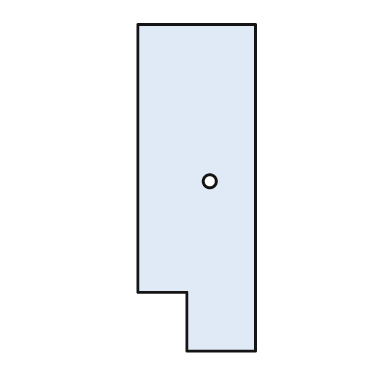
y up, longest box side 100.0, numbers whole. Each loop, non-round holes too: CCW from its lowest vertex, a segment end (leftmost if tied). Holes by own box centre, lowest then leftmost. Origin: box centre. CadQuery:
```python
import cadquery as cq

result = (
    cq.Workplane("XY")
    .moveTo(-3.0, -50.0)
    .lineTo(18.0, -50.0)
    .lineTo(18.0, 50.0)
    .lineTo(-18.0, 50.0)
    .lineTo(-18.0, -32.0)
    .lineTo(-3.0, -32.0)
    .close()
    .moveTo(4.0, 2.0)
    .circle(2.0)
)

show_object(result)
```